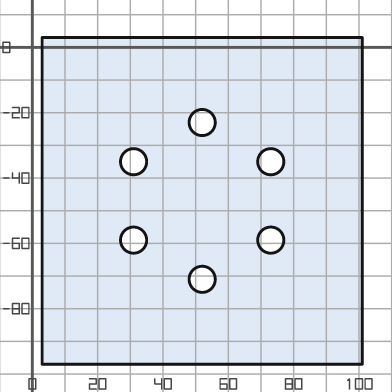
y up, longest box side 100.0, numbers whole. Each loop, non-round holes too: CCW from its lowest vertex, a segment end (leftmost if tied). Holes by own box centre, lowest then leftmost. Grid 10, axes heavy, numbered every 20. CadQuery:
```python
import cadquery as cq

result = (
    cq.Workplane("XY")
    .moveTo(3.0, -97.0)
    .lineTo(101.0, -97.0)
    .lineTo(101.0, 3.0)
    .lineTo(3.0, 3.0)
    .close()
    .moveTo(52.0, -71.0)
    .circle(4.0)
    .moveTo(31.0, -59.0)
    .circle(4.0)
    .moveTo(73.0, -59.0)
    .circle(4.0)
    .moveTo(31.0, -35.0)
    .circle(4.0)
    .moveTo(73.0, -35.0)
    .circle(4.0)
    .moveTo(52.0, -23.0)
    .circle(4.0)
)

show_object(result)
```